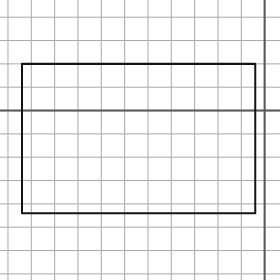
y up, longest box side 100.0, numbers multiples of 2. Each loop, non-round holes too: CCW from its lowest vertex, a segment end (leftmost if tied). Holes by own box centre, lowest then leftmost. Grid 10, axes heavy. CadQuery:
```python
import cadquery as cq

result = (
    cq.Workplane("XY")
    .moveTo(-104.0, -44.0)
    .lineTo(-4.0, -44.0)
    .lineTo(-4.0, 20.0)
    .lineTo(-104.0, 20.0)
    .close()
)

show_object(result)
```